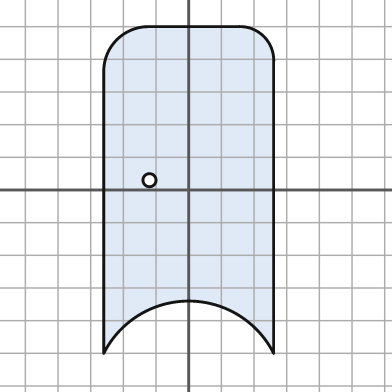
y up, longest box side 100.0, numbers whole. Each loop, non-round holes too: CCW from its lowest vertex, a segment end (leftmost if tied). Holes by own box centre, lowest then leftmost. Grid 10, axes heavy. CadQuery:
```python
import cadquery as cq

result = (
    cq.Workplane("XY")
    .moveTo(-26.0, -50.0)
    .threePointArc((0.0, -34.0), (26.0, -50.0))
    .lineTo(26.0, 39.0)
    .threePointArc((23.0, 47.0), (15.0, 50.0))
    .lineTo(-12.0, 50.0)
    .threePointArc((-22.0, 46.0), (-26.0, 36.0))
    .close()
    .moveTo(-12.0, 3.0)
    .circle(2.0)
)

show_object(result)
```